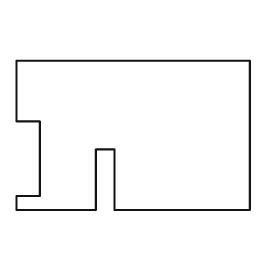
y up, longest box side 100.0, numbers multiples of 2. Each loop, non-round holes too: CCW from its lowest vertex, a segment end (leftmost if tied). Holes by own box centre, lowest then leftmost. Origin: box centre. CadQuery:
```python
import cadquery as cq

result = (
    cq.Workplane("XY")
    .moveTo(-50.0, -32.0)
    .lineTo(-16.0, -32.0)
    .lineTo(-16.0, -6.0)
    .lineTo(-8.0, -6.0)
    .lineTo(-8.0, -32.0)
    .lineTo(50.0, -32.0)
    .lineTo(50.0, 32.0)
    .lineTo(-50.0, 32.0)
    .lineTo(-50.0, 6.0)
    .lineTo(-40.0, 6.0)
    .lineTo(-40.0, -26.0)
    .lineTo(-50.0, -26.0)
    .close()
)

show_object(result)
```